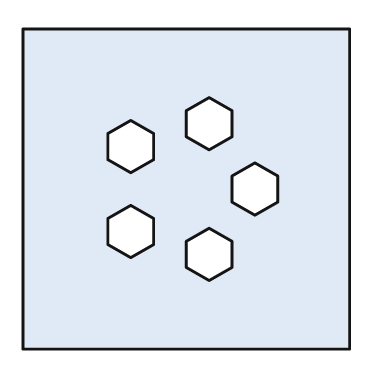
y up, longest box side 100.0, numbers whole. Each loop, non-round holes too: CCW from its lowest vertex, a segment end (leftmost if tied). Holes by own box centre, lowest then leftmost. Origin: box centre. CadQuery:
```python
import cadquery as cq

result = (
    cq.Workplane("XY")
    .moveTo(-50.0, -49.0)
    .lineTo(50.0, -49.0)
    .lineTo(50.0, 49.0)
    .lineTo(-50.0, 49.0)
    .close()
    .moveTo(7.0, -28.0)
    .lineTo(14.0, -24.0)
    .lineTo(14.0, -16.0)
    .lineTo(7.0, -12.0)
    .lineTo(0.0, -16.0)
    .lineTo(0.0, -24.0)
    .close()
    .moveTo(-17.0, -21.0)
    .lineTo(-10.0, -17.0)
    .lineTo(-10.0, -9.0)
    .lineTo(-17.0, -5.0)
    .lineTo(-24.0, -9.0)
    .lineTo(-24.0, -17.0)
    .close()
    .moveTo(21.0, -8.0)
    .lineTo(28.0, -4.0)
    .lineTo(28.0, 4.0)
    .lineTo(21.0, 8.0)
    .lineTo(14.0, 4.0)
    .lineTo(14.0, -4.0)
    .close()
    .moveTo(-17.0, 5.0)
    .lineTo(-10.0, 9.0)
    .lineTo(-10.0, 17.0)
    .lineTo(-17.0, 21.0)
    .lineTo(-24.0, 17.0)
    .lineTo(-24.0, 9.0)
    .close()
    .moveTo(7.0, 12.0)
    .lineTo(14.0, 16.0)
    .lineTo(14.0, 24.0)
    .lineTo(7.0, 28.0)
    .lineTo(0.0, 24.0)
    .lineTo(0.0, 16.0)
    .close()
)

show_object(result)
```